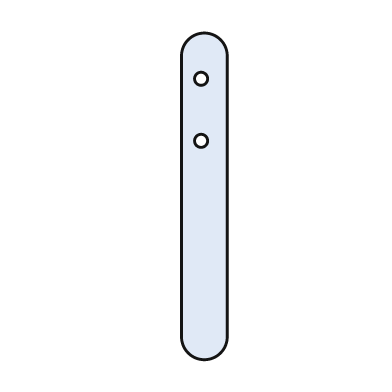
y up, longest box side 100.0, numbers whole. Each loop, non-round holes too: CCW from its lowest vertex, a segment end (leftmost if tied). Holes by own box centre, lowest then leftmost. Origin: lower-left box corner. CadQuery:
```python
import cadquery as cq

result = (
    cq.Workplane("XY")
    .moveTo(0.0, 7.0)
    .threePointArc((7.0, 0.0), (14.0, 7.0))
    .lineTo(14.0, 93.0)
    .threePointArc((7.0, 100.0), (0.0, 93.0))
    .close()
    .moveTo(6.0, 67.0)
    .circle(2.0)
    .moveTo(6.0, 86.0)
    .circle(2.0)
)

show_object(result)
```